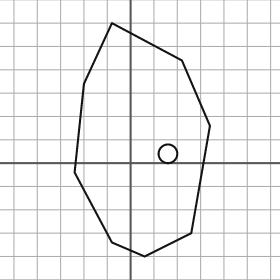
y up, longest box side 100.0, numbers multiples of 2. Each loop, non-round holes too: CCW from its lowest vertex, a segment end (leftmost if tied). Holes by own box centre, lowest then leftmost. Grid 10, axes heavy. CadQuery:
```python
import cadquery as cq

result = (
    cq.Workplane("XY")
    .moveTo(6.0, -40.0)
    .lineTo(26.0, -30.0)
    .lineTo(34.0, 16.0)
    .lineTo(22.0, 44.0)
    .lineTo(-8.0, 60.0)
    .lineTo(-20.0, 34.0)
    .lineTo(-24.0, -4.0)
    .lineTo(-8.0, -34.0)
    .close()
    .moveTo(16.0, 4.0)
    .circle(4.0)
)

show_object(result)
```